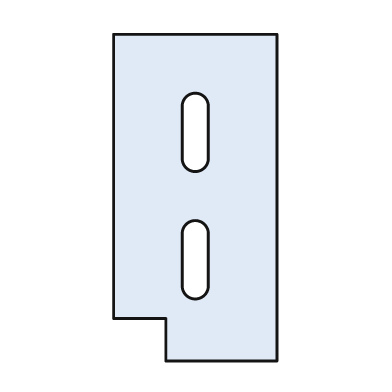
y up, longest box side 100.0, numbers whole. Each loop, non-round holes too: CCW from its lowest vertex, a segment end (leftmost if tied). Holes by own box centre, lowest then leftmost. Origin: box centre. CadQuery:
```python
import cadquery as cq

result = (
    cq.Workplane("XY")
    .moveTo(-9.0, -50.0)
    .lineTo(25.0, -50.0)
    .lineTo(25.0, 50.0)
    .lineTo(-25.0, 50.0)
    .lineTo(-25.0, -37.0)
    .lineTo(-9.0, -37.0)
    .close()
    .moveTo(-4.0, -27.0)
    .threePointArc((0.0, -31.0), (4.0, -27.0))
    .lineTo(4.0, -11.0)
    .threePointArc((0.0, -7.0), (-4.0, -11.0))
    .close()
    .moveTo(-4.0, 12.0)
    .threePointArc((0.0, 8.0), (4.0, 12.0))
    .lineTo(4.0, 28.0)
    .threePointArc((0.0, 32.0), (-4.0, 28.0))
    .close()
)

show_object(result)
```